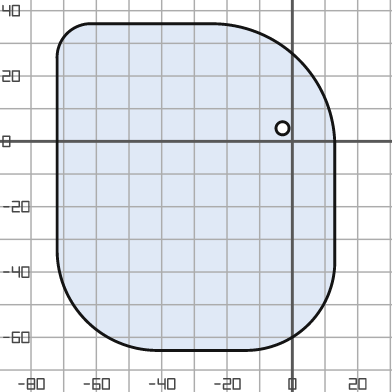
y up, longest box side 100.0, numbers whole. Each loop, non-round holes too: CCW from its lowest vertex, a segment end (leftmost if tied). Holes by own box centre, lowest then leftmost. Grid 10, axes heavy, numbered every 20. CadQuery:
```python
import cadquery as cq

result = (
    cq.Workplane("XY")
    .moveTo(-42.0, -64.0)
    .lineTo(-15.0, -64.0)
    .threePointArc((5.0, -56.0), (13.0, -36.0))
    .lineTo(13.0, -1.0)
    .threePointArc((2.0, 25.0), (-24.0, 36.0))
    .lineTo(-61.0, 36.0)
    .threePointArc((-69.0, 33.0), (-72.0, 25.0))
    .lineTo(-72.0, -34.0)
    .threePointArc((-63.0, -55.0), (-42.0, -64.0))
    .close()
    .moveTo(-3.0, 4.0)
    .circle(2.0)
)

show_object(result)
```